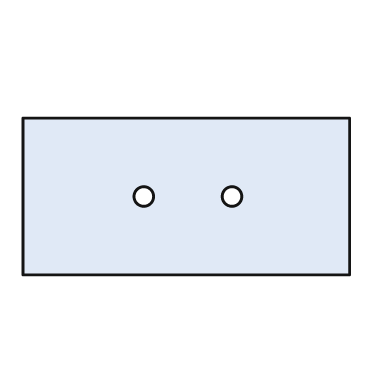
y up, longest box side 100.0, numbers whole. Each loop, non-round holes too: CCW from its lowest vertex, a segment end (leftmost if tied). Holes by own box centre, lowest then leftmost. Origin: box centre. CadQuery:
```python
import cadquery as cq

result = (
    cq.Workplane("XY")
    .moveTo(-50.0, -24.0)
    .lineTo(50.0, -24.0)
    .lineTo(50.0, 24.0)
    .lineTo(-50.0, 24.0)
    .close()
    .moveTo(-13.0, 0.0)
    .circle(3.0)
    .moveTo(14.0, 0.0)
    .circle(3.0)
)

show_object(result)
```